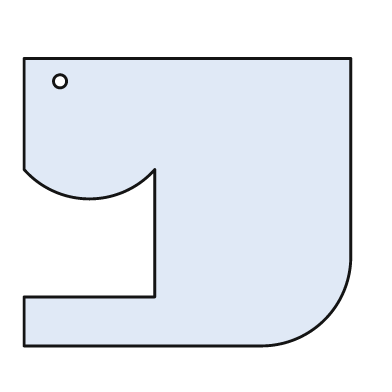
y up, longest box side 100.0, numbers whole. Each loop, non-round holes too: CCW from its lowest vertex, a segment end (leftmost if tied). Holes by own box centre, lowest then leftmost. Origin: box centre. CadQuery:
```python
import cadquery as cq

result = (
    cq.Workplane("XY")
    .moveTo(-50.0, -44.0)
    .lineTo(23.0, -44.0)
    .threePointArc((42.0, -36.0), (50.0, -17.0))
    .lineTo(50.0, 44.0)
    .lineTo(-50.0, 44.0)
    .lineTo(-50.0, 10.0)
    .threePointArc((-30.0, 1.0), (-10.0, 10.0))
    .lineTo(-10.0, -29.0)
    .lineTo(-50.0, -29.0)
    .close()
    .moveTo(-39.0, 37.0)
    .circle(2.0)
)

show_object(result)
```